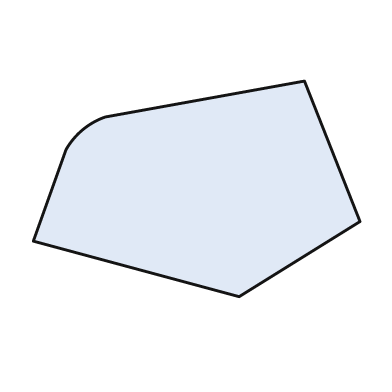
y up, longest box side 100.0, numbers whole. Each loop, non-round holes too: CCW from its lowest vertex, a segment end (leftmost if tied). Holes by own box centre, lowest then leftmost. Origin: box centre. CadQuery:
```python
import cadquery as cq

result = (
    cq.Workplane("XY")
    .moveTo(13.0, -33.0)
    .lineTo(50.0, -10.0)
    .lineTo(33.0, 33.0)
    .lineTo(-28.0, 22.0)
    .threePointArc((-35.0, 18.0), (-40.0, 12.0))
    .lineTo(-50.0, -16.0)
    .close()
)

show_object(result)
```